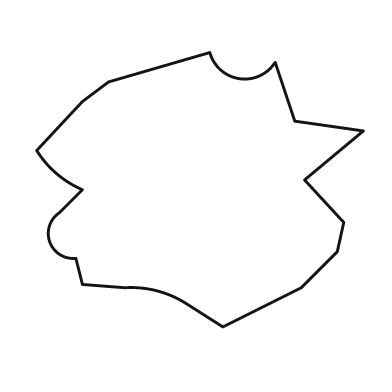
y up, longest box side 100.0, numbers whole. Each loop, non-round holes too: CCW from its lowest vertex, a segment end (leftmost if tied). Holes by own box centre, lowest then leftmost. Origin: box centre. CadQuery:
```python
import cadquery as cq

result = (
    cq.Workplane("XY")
    .moveTo(7.0, -42.0)
    .lineTo(31.0, -30.0)
    .lineTo(42.0, -19.0)
    .lineTo(44.0, -10.0)
    .lineTo(32.0, 3.0)
    .lineTo(50.0, 18.0)
    .lineTo(29.0, 21.0)
    .lineTo(23.0, 39.0)
    .threePointArc((12.0, 34.0), (3.0, 42.0))
    .lineTo(-28.0, 33.0)
    .lineTo(-36.0, 27.0)
    .lineTo(-50.0, 12.0)
    .threePointArc((-44.0, 5.0), (-36.0, 0.0))
    .lineTo(-43.0, -7.0)
    .threePointArc((-46.0, -16.0), (-38.0, -21.0))
    .lineTo(-36.0, -29.0)
    .lineTo(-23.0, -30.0)
    .threePointArc((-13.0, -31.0), (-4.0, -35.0))
    .close()
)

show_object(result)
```